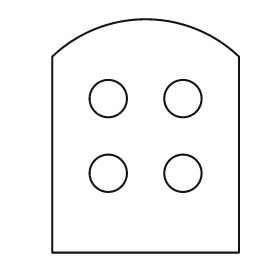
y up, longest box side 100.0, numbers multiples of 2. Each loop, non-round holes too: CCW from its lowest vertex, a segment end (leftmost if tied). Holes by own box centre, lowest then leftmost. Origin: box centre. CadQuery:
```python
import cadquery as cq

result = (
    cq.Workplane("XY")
    .moveTo(-40.0, -50.0)
    .lineTo(40.0, -50.0)
    .lineTo(40.0, 34.0)
    .threePointArc((0.0, 50.0), (-40.0, 34.0))
    .close()
    .moveTo(-16.0, -16.0)
    .circle(8.0)
    .moveTo(16.0, -16.0)
    .circle(8.0)
    .moveTo(-16.0, 16.0)
    .circle(8.0)
    .moveTo(16.0, 16.0)
    .circle(8.0)
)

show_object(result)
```